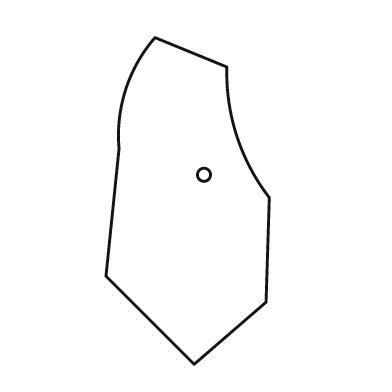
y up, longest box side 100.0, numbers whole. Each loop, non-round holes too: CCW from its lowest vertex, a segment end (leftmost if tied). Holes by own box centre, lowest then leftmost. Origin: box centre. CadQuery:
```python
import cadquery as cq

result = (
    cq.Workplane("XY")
    .moveTo(2.0, -50.0)
    .lineTo(24.0, -31.0)
    .lineTo(25.0, 1.0)
    .threePointArc((15.0, 20.0), (12.0, 41.0))
    .lineTo(-10.0, 50.0)
    .threePointArc((-19.0, 34.0), (-21.0, 16.0))
    .lineTo(-25.0, -23.0)
    .close()
    .moveTo(5.0, 8.0)
    .circle(2.0)
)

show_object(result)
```